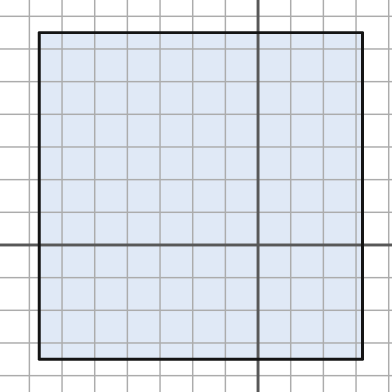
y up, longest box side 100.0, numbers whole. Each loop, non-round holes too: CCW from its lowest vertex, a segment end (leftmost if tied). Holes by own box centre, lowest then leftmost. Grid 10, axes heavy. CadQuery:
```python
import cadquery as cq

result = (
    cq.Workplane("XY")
    .moveTo(-67.0, -35.0)
    .lineTo(32.0, -35.0)
    .lineTo(32.0, 65.0)
    .lineTo(-67.0, 65.0)
    .close()
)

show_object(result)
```